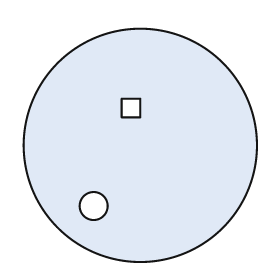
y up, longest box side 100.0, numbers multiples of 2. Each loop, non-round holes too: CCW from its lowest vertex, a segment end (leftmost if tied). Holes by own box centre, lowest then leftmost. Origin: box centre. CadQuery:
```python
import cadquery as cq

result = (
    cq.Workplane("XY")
    .moveTo(0.0, 0.0)
    .circle(50.0)
    .moveTo(-20.0, -26.0)
    .circle(6.0)
    .moveTo(-8.0, 12.0)
    .lineTo(0.0, 12.0)
    .lineTo(0.0, 20.0)
    .lineTo(-8.0, 20.0)
    .close()
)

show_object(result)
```